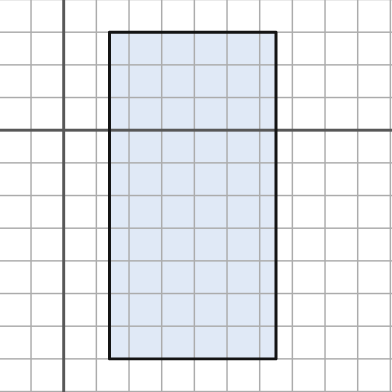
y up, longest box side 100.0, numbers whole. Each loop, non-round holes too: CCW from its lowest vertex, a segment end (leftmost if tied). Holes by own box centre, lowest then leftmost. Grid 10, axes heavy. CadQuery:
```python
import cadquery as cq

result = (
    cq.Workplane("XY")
    .moveTo(14.0, -70.0)
    .lineTo(65.0, -70.0)
    .lineTo(65.0, 30.0)
    .lineTo(14.0, 30.0)
    .close()
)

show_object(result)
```